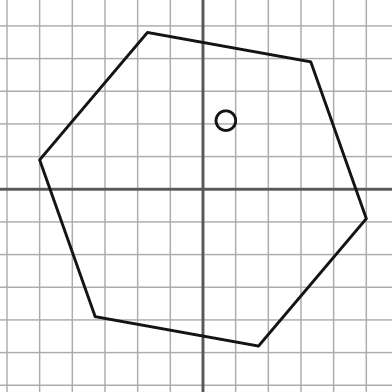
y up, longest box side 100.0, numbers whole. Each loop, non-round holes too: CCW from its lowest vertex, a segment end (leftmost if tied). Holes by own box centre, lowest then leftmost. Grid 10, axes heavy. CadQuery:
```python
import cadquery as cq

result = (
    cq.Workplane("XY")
    .moveTo(17.0, -48.0)
    .lineTo(50.0, -9.0)
    .lineTo(33.0, 39.0)
    .lineTo(-17.0, 48.0)
    .lineTo(-50.0, 9.0)
    .lineTo(-33.0, -39.0)
    .close()
    .moveTo(7.0, 21.0)
    .circle(3.0)
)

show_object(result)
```